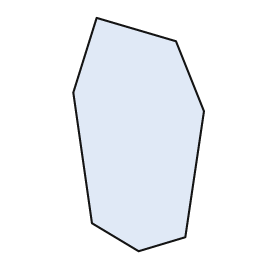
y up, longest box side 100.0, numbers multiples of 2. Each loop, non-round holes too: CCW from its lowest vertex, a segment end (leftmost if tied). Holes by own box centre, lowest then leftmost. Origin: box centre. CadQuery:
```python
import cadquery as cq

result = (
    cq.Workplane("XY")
    .moveTo(0.0, -50.0)
    .lineTo(20.0, -44.0)
    .lineTo(28.0, 10.0)
    .lineTo(16.0, 40.0)
    .lineTo(-18.0, 50.0)
    .lineTo(-28.0, 18.0)
    .lineTo(-20.0, -38.0)
    .close()
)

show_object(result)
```